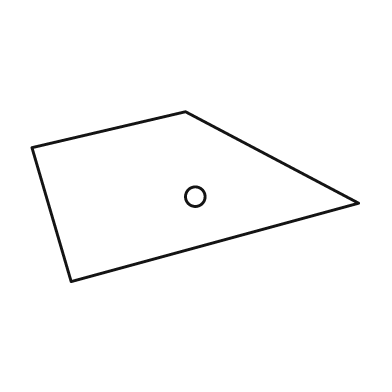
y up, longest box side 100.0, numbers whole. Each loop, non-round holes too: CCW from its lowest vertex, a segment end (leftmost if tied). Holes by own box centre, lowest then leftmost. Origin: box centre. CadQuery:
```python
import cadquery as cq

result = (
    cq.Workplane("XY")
    .moveTo(-38.0, -26.0)
    .lineTo(50.0, -2.0)
    .lineTo(-3.0, 26.0)
    .lineTo(-50.0, 15.0)
    .close()
    .moveTo(0.0, 0.0)
    .circle(3.0)
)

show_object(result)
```